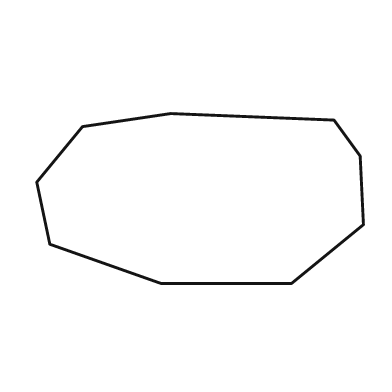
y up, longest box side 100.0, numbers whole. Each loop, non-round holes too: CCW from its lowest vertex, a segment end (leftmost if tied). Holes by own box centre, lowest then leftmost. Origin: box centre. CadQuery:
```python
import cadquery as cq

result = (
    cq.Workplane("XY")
    .moveTo(-12.0, -26.0)
    .lineTo(28.0, -26.0)
    .lineTo(50.0, -8.0)
    .lineTo(49.0, 13.0)
    .lineTo(41.0, 24.0)
    .lineTo(-9.0, 26.0)
    .lineTo(-36.0, 22.0)
    .lineTo(-50.0, 5.0)
    .lineTo(-46.0, -14.0)
    .close()
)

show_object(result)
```